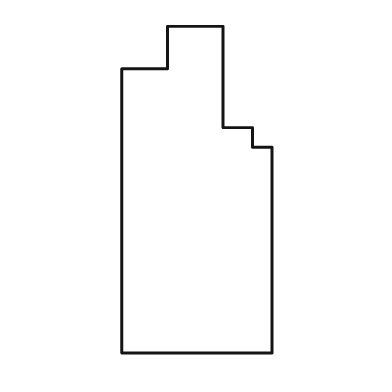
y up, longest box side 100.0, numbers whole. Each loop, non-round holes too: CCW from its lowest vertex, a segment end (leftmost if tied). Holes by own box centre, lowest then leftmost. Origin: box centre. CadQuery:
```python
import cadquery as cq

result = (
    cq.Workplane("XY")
    .moveTo(-23.0, -50.0)
    .lineTo(23.0, -50.0)
    .lineTo(23.0, 13.0)
    .lineTo(17.0, 13.0)
    .lineTo(17.0, 19.0)
    .lineTo(8.0, 19.0)
    .lineTo(8.0, 50.0)
    .lineTo(-9.0, 50.0)
    .lineTo(-9.0, 37.0)
    .lineTo(-23.0, 37.0)
    .close()
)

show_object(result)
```